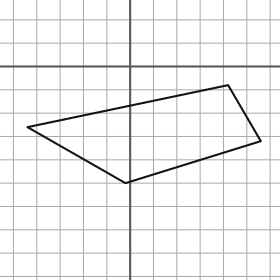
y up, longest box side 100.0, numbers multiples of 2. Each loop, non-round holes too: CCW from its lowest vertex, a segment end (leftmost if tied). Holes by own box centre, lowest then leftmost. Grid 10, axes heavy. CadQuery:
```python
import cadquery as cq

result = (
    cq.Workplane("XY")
    .moveTo(-2.0, -50.0)
    .lineTo(56.0, -32.0)
    .lineTo(42.0, -8.0)
    .lineTo(-44.0, -26.0)
    .close()
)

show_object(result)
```